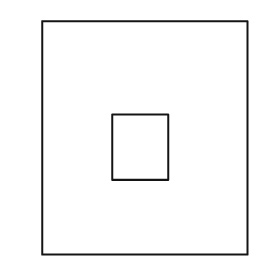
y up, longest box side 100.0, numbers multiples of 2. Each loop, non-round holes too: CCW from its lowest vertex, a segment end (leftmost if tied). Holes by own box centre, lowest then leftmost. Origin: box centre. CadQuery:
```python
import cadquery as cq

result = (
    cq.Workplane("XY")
    .moveTo(-44.0, -50.0)
    .lineTo(44.0, -50.0)
    .lineTo(44.0, 50.0)
    .lineTo(-44.0, 50.0)
    .close()
    .moveTo(-14.0, -18.0)
    .lineTo(10.0, -18.0)
    .lineTo(10.0, 10.0)
    .lineTo(-14.0, 10.0)
    .close()
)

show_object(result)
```